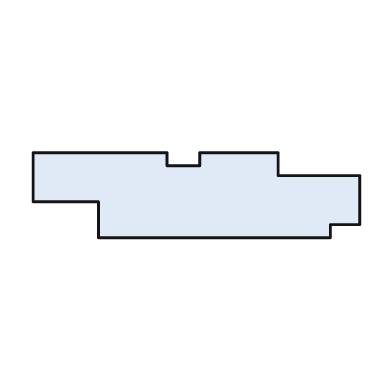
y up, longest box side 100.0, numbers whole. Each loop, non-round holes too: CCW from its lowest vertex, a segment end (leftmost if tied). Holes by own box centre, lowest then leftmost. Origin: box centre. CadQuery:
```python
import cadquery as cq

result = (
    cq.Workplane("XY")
    .moveTo(-30.0, -13.0)
    .lineTo(41.0, -13.0)
    .lineTo(41.0, -9.0)
    .lineTo(50.0, -9.0)
    .lineTo(50.0, 6.0)
    .lineTo(25.0, 6.0)
    .lineTo(25.0, 13.0)
    .lineTo(1.0, 13.0)
    .lineTo(1.0, 9.0)
    .lineTo(-9.0, 9.0)
    .lineTo(-9.0, 13.0)
    .lineTo(-50.0, 13.0)
    .lineTo(-50.0, -2.0)
    .lineTo(-30.0, -2.0)
    .close()
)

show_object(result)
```